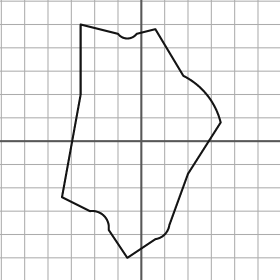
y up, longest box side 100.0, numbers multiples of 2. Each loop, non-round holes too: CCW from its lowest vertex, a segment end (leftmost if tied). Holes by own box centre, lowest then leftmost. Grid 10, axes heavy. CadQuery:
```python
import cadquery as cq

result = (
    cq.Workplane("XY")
    .moveTo(-6.0, -50.0)
    .lineTo(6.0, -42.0)
    .threePointArc((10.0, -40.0), (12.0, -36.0))
    .lineTo(20.0, -14.0)
    .lineTo(34.0, 8.0)
    .threePointArc((28.0, 20.0), (18.0, 28.0))
    .lineTo(6.0, 48.0)
    .lineTo(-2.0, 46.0)
    .threePointArc((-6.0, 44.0), (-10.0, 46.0))
    .lineTo(-26.0, 50.0)
    .lineTo(-26.0, 20.0)
    .lineTo(-34.0, -24.0)
    .lineTo(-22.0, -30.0)
    .threePointArc((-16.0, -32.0), (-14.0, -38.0))
    .close()
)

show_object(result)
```